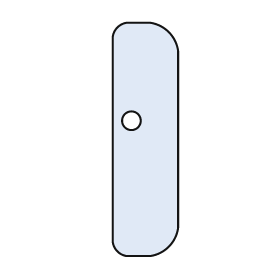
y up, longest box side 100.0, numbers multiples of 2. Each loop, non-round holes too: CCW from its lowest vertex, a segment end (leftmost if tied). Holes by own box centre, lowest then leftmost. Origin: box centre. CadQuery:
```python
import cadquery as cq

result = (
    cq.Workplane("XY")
    .moveTo(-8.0, -50.0)
    .lineTo(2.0, -50.0)
    .threePointArc((10.0, -46.0), (14.0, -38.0))
    .lineTo(14.0, 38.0)
    .threePointArc((10.0, 46.0), (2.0, 50.0))
    .lineTo(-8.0, 50.0)
    .threePointArc((-12.0, 48.0), (-14.0, 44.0))
    .lineTo(-14.0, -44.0)
    .threePointArc((-12.0, -48.0), (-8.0, -50.0))
    .close()
    .moveTo(-6.0, 8.0)
    .circle(4.0)
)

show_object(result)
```